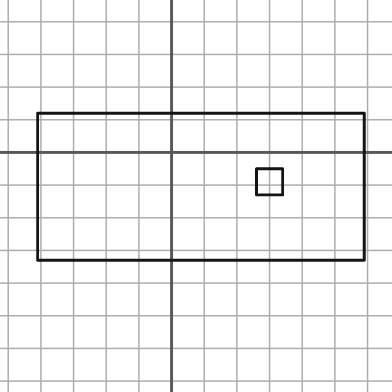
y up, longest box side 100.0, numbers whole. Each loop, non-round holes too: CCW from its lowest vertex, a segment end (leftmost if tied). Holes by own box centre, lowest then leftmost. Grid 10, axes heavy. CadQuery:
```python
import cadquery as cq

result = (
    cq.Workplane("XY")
    .moveTo(-41.0, -33.0)
    .lineTo(59.0, -33.0)
    .lineTo(59.0, 12.0)
    .lineTo(-41.0, 12.0)
    .close()
    .moveTo(26.0, -13.0)
    .lineTo(34.0, -13.0)
    .lineTo(34.0, -5.0)
    .lineTo(26.0, -5.0)
    .close()
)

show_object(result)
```